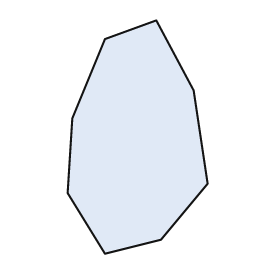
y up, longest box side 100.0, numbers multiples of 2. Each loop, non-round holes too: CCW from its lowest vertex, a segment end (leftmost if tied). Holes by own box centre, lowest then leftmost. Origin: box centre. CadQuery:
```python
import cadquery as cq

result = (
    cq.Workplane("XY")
    .moveTo(-14.0, -50.0)
    .lineTo(10.0, -44.0)
    .lineTo(30.0, -20.0)
    .lineTo(24.0, 20.0)
    .lineTo(8.0, 50.0)
    .lineTo(-14.0, 42.0)
    .lineTo(-28.0, 8.0)
    .lineTo(-30.0, -24.0)
    .close()
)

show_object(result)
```